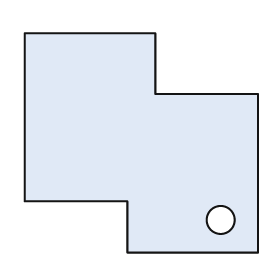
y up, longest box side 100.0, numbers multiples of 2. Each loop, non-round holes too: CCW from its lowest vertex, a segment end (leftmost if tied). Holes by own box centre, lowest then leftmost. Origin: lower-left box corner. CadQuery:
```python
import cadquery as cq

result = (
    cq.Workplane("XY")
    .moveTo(44.0, 0.0)
    .lineTo(100.0, 0.0)
    .lineTo(100.0, 68.0)
    .lineTo(56.0, 68.0)
    .lineTo(56.0, 94.0)
    .lineTo(0.0, 94.0)
    .lineTo(0.0, 22.0)
    .lineTo(44.0, 22.0)
    .close()
    .moveTo(84.0, 14.0)
    .circle(6.0)
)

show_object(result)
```